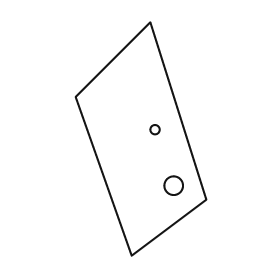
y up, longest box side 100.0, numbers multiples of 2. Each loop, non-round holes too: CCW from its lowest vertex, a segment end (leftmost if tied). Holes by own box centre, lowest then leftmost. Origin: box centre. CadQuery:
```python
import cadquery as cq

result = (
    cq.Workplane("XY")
    .moveTo(-4.0, -50.0)
    .lineTo(28.0, -26.0)
    .lineTo(4.0, 50.0)
    .lineTo(-28.0, 18.0)
    .close()
    .moveTo(14.0, -20.0)
    .circle(4.0)
    .moveTo(6.0, 4.0)
    .circle(2.0)
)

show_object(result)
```